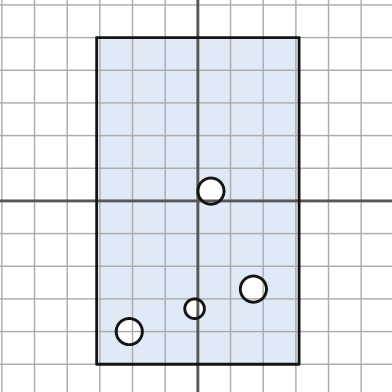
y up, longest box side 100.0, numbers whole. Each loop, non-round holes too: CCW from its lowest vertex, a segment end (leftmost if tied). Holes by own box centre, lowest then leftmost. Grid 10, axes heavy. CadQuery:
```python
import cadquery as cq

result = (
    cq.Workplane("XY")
    .moveTo(-31.0, -50.0)
    .lineTo(31.0, -50.0)
    .lineTo(31.0, 50.0)
    .lineTo(-31.0, 50.0)
    .close()
    .moveTo(-21.0, -40.0)
    .circle(4.0)
    .moveTo(-1.0, -33.0)
    .circle(3.0)
    .moveTo(17.0, -27.0)
    .circle(4.0)
    .moveTo(4.0, 3.0)
    .circle(4.0)
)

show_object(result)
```